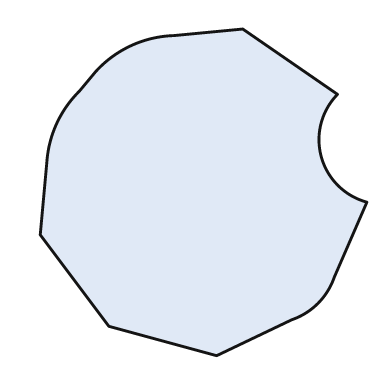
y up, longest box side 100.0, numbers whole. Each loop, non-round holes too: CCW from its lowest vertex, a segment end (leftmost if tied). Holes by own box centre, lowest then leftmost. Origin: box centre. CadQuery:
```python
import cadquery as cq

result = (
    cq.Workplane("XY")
    .moveTo(4.0, -50.0)
    .lineTo(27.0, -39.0)
    .threePointArc((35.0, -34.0), (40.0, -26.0))
    .lineTo(50.0, -3.0)
    .threePointArc((36.0, 11.0), (41.0, 30.0))
    .lineTo(12.0, 50.0)
    .lineTo(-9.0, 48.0)
    .threePointArc((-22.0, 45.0), (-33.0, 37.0))
    .lineTo(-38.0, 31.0)
    .threePointArc((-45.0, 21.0), (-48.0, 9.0))
    .lineTo(-50.0, -13.0)
    .lineTo(-29.0, -41.0)
    .close()
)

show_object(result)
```